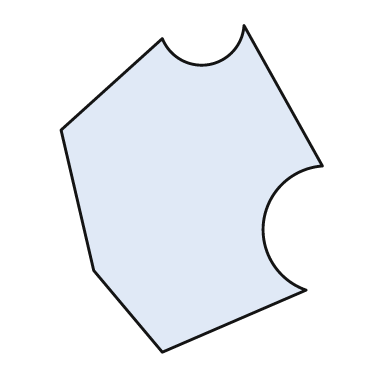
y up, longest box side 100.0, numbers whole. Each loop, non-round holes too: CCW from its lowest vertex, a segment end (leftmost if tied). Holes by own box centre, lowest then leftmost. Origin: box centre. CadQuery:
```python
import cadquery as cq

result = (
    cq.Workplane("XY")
    .moveTo(-9.0, -50.0)
    .lineTo(35.0, -31.0)
    .threePointArc((22.0, -10.0), (40.0, 7.0))
    .lineTo(16.0, 50.0)
    .threePointArc((5.0, 38.0), (-9.0, 46.0))
    .lineTo(-40.0, 18.0)
    .lineTo(-30.0, -25.0)
    .close()
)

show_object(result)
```